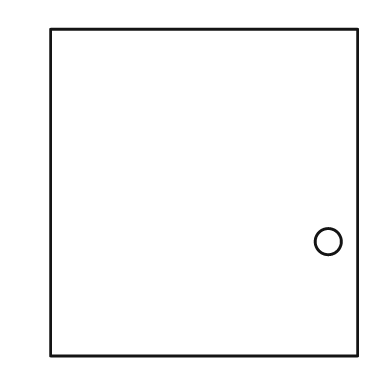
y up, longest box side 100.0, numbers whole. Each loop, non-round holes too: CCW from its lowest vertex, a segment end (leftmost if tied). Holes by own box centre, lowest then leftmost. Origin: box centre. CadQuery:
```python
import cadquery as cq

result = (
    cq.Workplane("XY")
    .moveTo(-47.0, -50.0)
    .lineTo(47.0, -50.0)
    .lineTo(47.0, 50.0)
    .lineTo(-47.0, 50.0)
    .close()
    .moveTo(38.0, -15.0)
    .circle(4.0)
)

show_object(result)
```